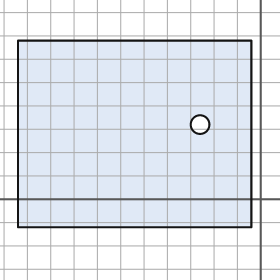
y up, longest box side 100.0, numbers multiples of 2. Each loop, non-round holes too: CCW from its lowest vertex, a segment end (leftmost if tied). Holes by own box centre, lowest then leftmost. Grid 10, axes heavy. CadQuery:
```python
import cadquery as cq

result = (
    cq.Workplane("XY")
    .moveTo(-104.0, -12.0)
    .lineTo(-4.0, -12.0)
    .lineTo(-4.0, 68.0)
    .lineTo(-104.0, 68.0)
    .close()
    .moveTo(-26.0, 32.0)
    .circle(4.0)
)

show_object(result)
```